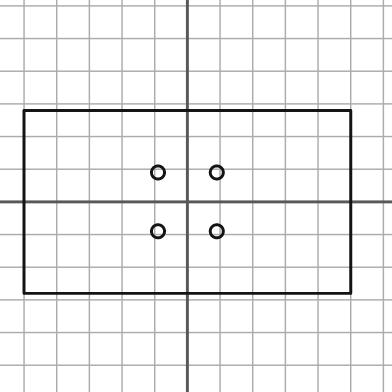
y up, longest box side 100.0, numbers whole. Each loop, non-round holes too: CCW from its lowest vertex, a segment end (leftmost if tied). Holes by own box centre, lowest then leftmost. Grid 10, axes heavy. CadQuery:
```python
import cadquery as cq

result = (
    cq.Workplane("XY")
    .moveTo(-50.0, -28.0)
    .lineTo(50.0, -28.0)
    .lineTo(50.0, 28.0)
    .lineTo(-50.0, 28.0)
    .close()
    .moveTo(-9.0, -9.0)
    .circle(2.0)
    .moveTo(9.0, -9.0)
    .circle(2.0)
    .moveTo(-9.0, 9.0)
    .circle(2.0)
    .moveTo(9.0, 9.0)
    .circle(2.0)
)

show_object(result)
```